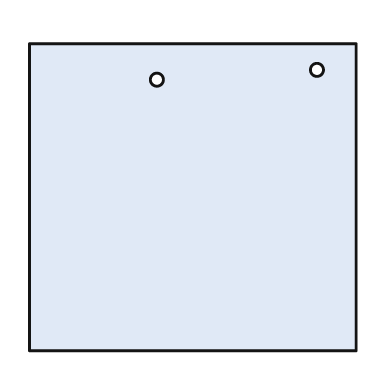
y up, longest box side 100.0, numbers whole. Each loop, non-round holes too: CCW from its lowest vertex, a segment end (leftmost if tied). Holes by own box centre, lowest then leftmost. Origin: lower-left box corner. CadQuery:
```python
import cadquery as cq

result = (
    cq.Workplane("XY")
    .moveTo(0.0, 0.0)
    .lineTo(100.0, 0.0)
    .lineTo(100.0, 94.0)
    .lineTo(0.0, 94.0)
    .close()
    .moveTo(39.0, 83.0)
    .circle(2.0)
    .moveTo(88.0, 86.0)
    .circle(2.0)
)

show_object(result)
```